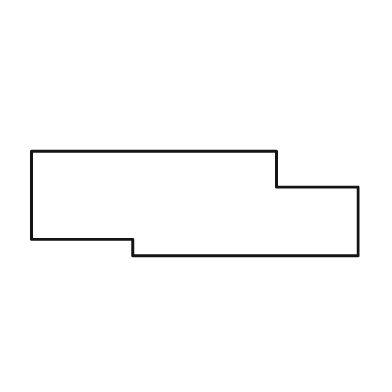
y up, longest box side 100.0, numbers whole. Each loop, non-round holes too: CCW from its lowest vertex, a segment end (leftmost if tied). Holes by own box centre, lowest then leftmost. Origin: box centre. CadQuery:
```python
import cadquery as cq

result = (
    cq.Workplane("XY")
    .moveTo(-19.0, -16.0)
    .lineTo(50.0, -16.0)
    .lineTo(50.0, 5.0)
    .lineTo(25.0, 5.0)
    .lineTo(25.0, 16.0)
    .lineTo(-50.0, 16.0)
    .lineTo(-50.0, -11.0)
    .lineTo(-19.0, -11.0)
    .close()
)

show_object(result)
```